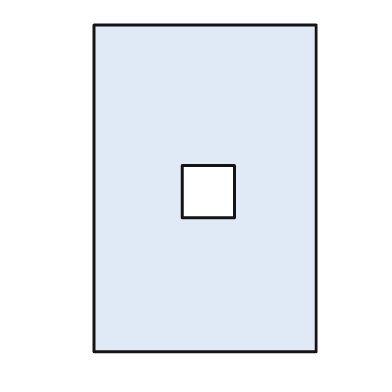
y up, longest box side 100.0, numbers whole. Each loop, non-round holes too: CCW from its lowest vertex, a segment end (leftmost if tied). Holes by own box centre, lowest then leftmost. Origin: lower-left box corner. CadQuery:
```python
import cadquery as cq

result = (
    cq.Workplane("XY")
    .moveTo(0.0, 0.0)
    .lineTo(68.0, 0.0)
    .lineTo(68.0, 100.0)
    .lineTo(0.0, 100.0)
    .close()
    .moveTo(27.0, 41.0)
    .lineTo(43.0, 41.0)
    .lineTo(43.0, 57.0)
    .lineTo(27.0, 57.0)
    .close()
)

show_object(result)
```